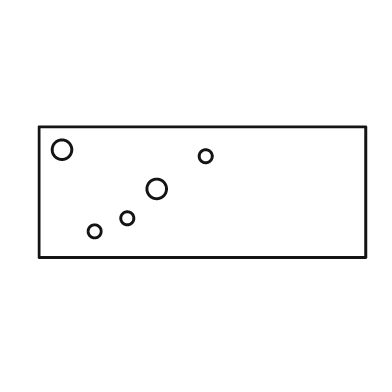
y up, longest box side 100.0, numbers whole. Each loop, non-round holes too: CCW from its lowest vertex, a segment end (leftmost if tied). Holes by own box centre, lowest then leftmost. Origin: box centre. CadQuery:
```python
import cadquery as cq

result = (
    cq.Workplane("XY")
    .moveTo(-50.0, -20.0)
    .lineTo(50.0, -20.0)
    .lineTo(50.0, 20.0)
    .lineTo(-50.0, 20.0)
    .close()
    .moveTo(-33.0, -12.0)
    .circle(2.0)
    .moveTo(-23.0, -8.0)
    .circle(2.0)
    .moveTo(-14.0, 1.0)
    .circle(3.0)
    .moveTo(1.0, 11.0)
    .circle(2.0)
    .moveTo(-43.0, 13.0)
    .circle(3.0)
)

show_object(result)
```